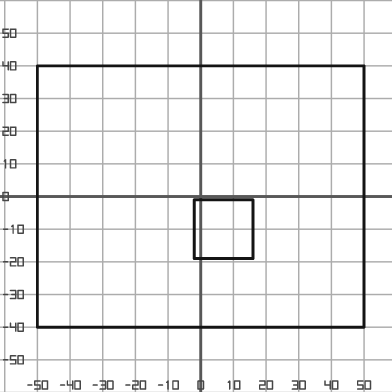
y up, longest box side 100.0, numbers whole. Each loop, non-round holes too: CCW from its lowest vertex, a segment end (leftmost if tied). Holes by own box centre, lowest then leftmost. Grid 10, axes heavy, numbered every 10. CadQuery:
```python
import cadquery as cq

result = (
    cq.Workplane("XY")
    .moveTo(-50.0, -40.0)
    .lineTo(50.0, -40.0)
    .lineTo(50.0, 40.0)
    .lineTo(-50.0, 40.0)
    .close()
    .moveTo(-2.0, -19.0)
    .lineTo(16.0, -19.0)
    .lineTo(16.0, -1.0)
    .lineTo(-2.0, -1.0)
    .close()
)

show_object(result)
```